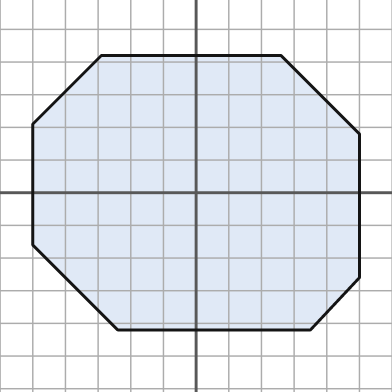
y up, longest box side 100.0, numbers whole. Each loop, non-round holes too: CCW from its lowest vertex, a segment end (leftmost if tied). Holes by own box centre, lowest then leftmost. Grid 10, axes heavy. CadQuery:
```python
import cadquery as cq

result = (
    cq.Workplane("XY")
    .moveTo(-24.0, -42.0)
    .lineTo(35.0, -42.0)
    .lineTo(50.0, -26.0)
    .lineTo(50.0, 18.0)
    .lineTo(26.0, 42.0)
    .lineTo(-29.0, 42.0)
    .lineTo(-50.0, 21.0)
    .lineTo(-50.0, -16.0)
    .close()
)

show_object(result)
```